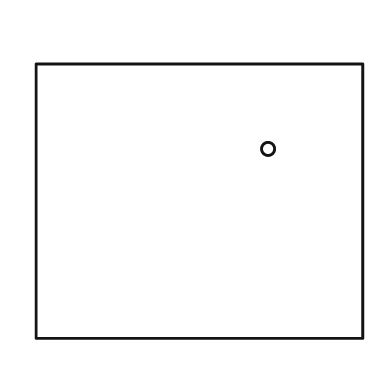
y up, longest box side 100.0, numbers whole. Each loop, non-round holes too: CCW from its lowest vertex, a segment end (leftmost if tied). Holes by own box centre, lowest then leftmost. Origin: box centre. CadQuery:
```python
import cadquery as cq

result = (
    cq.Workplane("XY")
    .moveTo(-50.0, -42.0)
    .lineTo(50.0, -42.0)
    .lineTo(50.0, 42.0)
    .lineTo(-50.0, 42.0)
    .close()
    .moveTo(21.0, 16.0)
    .circle(2.0)
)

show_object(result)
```